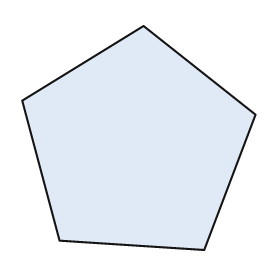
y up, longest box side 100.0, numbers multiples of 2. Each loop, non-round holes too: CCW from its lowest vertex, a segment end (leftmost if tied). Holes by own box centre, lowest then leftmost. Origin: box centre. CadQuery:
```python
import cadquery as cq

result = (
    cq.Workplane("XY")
    .moveTo(28.0, -48.0)
    .lineTo(50.0, 10.0)
    .lineTo(2.0, 48.0)
    .lineTo(-50.0, 16.0)
    .lineTo(-34.0, -44.0)
    .close()
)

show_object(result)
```